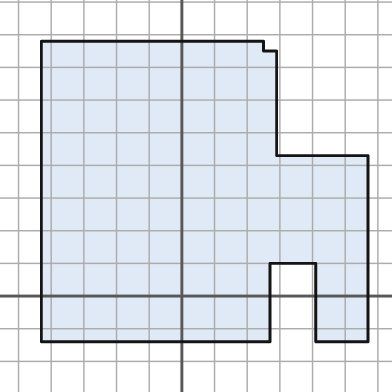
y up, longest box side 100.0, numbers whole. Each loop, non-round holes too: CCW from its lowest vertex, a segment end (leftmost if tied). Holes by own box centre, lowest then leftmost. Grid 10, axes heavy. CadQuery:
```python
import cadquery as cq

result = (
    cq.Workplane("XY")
    .moveTo(-43.0, -14.0)
    .lineTo(27.0, -14.0)
    .lineTo(27.0, 10.0)
    .lineTo(41.0, 10.0)
    .lineTo(41.0, -14.0)
    .lineTo(57.0, -14.0)
    .lineTo(57.0, 43.0)
    .lineTo(29.0, 43.0)
    .lineTo(29.0, 75.0)
    .lineTo(25.0, 75.0)
    .lineTo(25.0, 78.0)
    .lineTo(-43.0, 78.0)
    .close()
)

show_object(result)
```